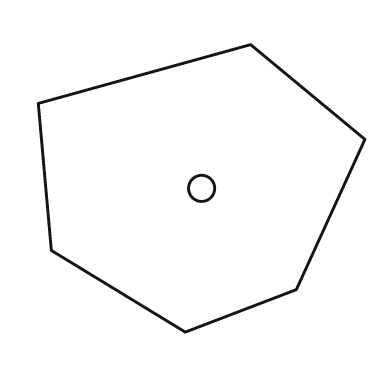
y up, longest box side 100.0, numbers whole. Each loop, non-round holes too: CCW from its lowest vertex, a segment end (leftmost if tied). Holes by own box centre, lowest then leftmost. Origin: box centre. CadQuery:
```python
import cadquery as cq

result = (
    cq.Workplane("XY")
    .moveTo(-5.0, -44.0)
    .lineTo(29.0, -31.0)
    .lineTo(50.0, 15.0)
    .lineTo(15.0, 44.0)
    .lineTo(-50.0, 26.0)
    .lineTo(-46.0, -19.0)
    .close()
    .moveTo(0.0, 0.0)
    .circle(4.0)
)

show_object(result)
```